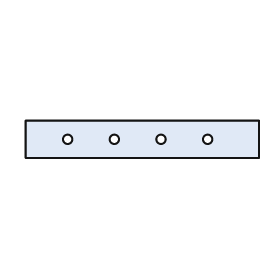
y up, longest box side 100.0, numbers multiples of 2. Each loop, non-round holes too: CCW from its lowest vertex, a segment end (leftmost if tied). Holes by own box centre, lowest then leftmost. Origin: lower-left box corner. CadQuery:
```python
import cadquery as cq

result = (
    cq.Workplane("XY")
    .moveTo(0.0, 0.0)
    .lineTo(100.0, 0.0)
    .lineTo(100.0, 16.0)
    .lineTo(0.0, 16.0)
    .close()
    .moveTo(18.0, 8.0)
    .circle(2.0)
    .moveTo(38.0, 8.0)
    .circle(2.0)
    .moveTo(58.0, 8.0)
    .circle(2.0)
    .moveTo(78.0, 8.0)
    .circle(2.0)
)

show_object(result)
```